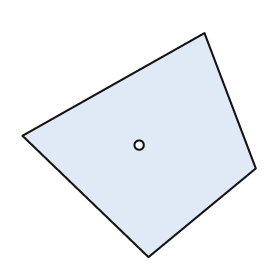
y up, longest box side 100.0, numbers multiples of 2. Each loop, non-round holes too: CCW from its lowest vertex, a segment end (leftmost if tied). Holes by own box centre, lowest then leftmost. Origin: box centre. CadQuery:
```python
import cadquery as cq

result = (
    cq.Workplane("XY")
    .moveTo(4.0, -48.0)
    .lineTo(50.0, -10.0)
    .lineTo(28.0, 48.0)
    .lineTo(-50.0, 4.0)
    .close()
    .moveTo(0.0, 0.0)
    .circle(2.0)
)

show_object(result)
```